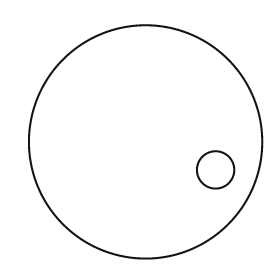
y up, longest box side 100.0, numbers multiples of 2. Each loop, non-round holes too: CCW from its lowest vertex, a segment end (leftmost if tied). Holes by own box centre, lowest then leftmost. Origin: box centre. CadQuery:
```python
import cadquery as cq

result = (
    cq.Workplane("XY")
    .moveTo(0.0, 0.0)
    .circle(50.0)
    .moveTo(30.0, -12.0)
    .circle(8.0)
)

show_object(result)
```